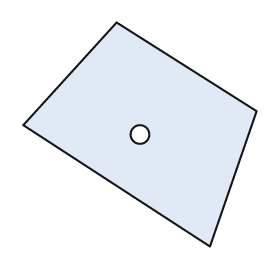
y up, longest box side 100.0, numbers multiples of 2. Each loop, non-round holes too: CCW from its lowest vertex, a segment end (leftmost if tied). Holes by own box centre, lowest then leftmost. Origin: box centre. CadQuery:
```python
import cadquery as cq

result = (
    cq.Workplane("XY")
    .moveTo(30.0, -48.0)
    .lineTo(50.0, 10.0)
    .lineTo(-10.0, 48.0)
    .lineTo(-50.0, 4.0)
    .close()
    .moveTo(0.0, 0.0)
    .circle(4.0)
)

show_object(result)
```